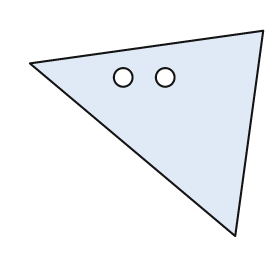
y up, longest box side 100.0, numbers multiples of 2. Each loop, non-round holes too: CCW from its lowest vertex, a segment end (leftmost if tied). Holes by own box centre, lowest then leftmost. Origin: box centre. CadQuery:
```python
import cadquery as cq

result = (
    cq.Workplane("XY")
    .moveTo(38.0, -44.0)
    .lineTo(50.0, 44.0)
    .lineTo(-50.0, 30.0)
    .close()
    .moveTo(-10.0, 24.0)
    .circle(4.0)
    .moveTo(8.0, 24.0)
    .circle(4.0)
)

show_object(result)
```